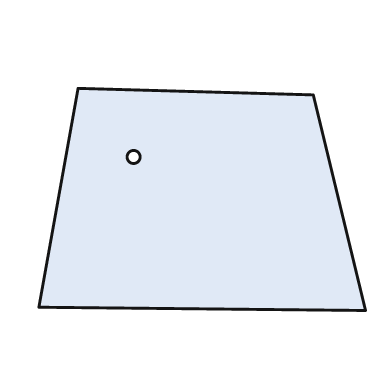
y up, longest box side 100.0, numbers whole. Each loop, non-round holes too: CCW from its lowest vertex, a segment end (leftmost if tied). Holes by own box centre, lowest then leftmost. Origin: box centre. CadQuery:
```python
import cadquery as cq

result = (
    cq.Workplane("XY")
    .moveTo(50.0, -34.0)
    .lineTo(34.0, 32.0)
    .lineTo(-38.0, 34.0)
    .lineTo(-50.0, -33.0)
    .close()
    .moveTo(-21.0, 13.0)
    .circle(2.0)
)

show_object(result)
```